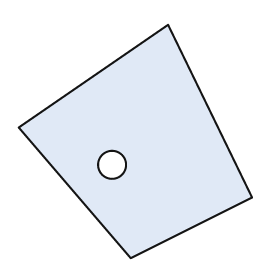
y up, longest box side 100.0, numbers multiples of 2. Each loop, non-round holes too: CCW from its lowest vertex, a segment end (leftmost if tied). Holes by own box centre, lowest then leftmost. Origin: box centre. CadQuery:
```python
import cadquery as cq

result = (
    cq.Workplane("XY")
    .moveTo(-2.0, -50.0)
    .lineTo(50.0, -24.0)
    .lineTo(14.0, 50.0)
    .lineTo(-50.0, 6.0)
    .close()
    .moveTo(-10.0, -10.0)
    .circle(6.0)
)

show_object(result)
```